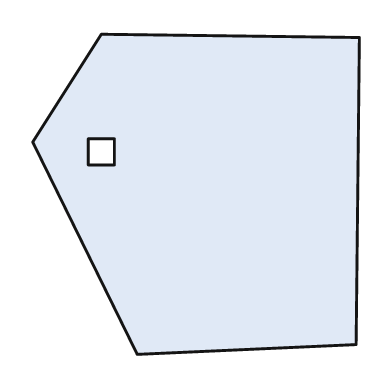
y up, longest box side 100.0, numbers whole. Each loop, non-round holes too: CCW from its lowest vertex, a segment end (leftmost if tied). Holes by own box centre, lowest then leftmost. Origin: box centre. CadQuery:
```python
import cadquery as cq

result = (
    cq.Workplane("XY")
    .moveTo(-18.0, -49.0)
    .lineTo(49.0, -46.0)
    .lineTo(50.0, 48.0)
    .lineTo(-29.0, 49.0)
    .lineTo(-50.0, 16.0)
    .close()
    .moveTo(-33.0, 9.0)
    .lineTo(-25.0, 9.0)
    .lineTo(-25.0, 17.0)
    .lineTo(-33.0, 17.0)
    .close()
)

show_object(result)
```